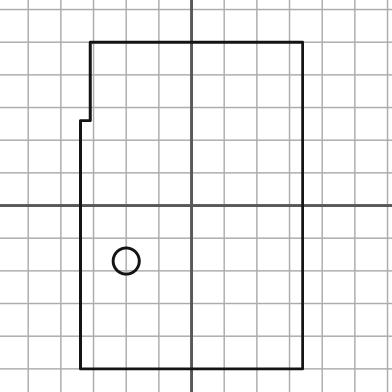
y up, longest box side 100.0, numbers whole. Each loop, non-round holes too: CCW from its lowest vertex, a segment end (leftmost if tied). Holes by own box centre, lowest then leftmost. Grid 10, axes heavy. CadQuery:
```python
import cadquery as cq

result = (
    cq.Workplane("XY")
    .moveTo(-34.0, -50.0)
    .lineTo(34.0, -50.0)
    .lineTo(34.0, 50.0)
    .lineTo(-31.0, 50.0)
    .lineTo(-31.0, 26.0)
    .lineTo(-34.0, 26.0)
    .close()
    .moveTo(-20.0, -17.0)
    .circle(4.0)
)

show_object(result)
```